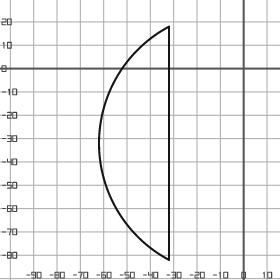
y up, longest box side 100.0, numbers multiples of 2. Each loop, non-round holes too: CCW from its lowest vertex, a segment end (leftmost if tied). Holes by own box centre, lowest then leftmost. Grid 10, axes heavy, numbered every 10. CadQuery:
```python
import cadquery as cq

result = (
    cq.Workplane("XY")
    .moveTo(-32.0, -82.0)
    .lineTo(-32.0, 18.0)
    .threePointArc((-62.0, -32.0), (-32.0, -82.0))
    .close()
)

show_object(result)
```